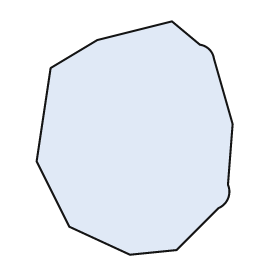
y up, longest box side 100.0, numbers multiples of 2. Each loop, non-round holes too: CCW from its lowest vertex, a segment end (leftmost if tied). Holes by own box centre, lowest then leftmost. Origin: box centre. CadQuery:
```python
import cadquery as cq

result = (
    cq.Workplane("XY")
    .moveTo(-2.0, -50.0)
    .lineTo(18.0, -48.0)
    .lineTo(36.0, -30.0)
    .threePointArc((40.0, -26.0), (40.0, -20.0))
    .lineTo(42.0, 6.0)
    .lineTo(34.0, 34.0)
    .threePointArc((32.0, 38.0), (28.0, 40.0))
    .lineTo(16.0, 50.0)
    .lineTo(-16.0, 42.0)
    .lineTo(-36.0, 30.0)
    .lineTo(-42.0, -10.0)
    .lineTo(-28.0, -38.0)
    .close()
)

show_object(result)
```